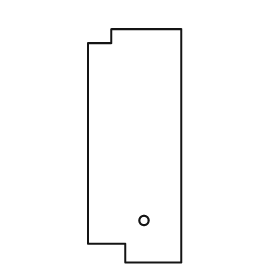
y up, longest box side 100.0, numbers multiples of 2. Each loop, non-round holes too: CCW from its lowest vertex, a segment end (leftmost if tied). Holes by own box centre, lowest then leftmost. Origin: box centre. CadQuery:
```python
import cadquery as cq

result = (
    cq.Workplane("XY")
    .moveTo(-4.0, -50.0)
    .lineTo(20.0, -50.0)
    .lineTo(20.0, 50.0)
    .lineTo(-10.0, 50.0)
    .lineTo(-10.0, 44.0)
    .lineTo(-20.0, 44.0)
    .lineTo(-20.0, -42.0)
    .lineTo(-4.0, -42.0)
    .close()
    .moveTo(4.0, -32.0)
    .circle(2.0)
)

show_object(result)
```